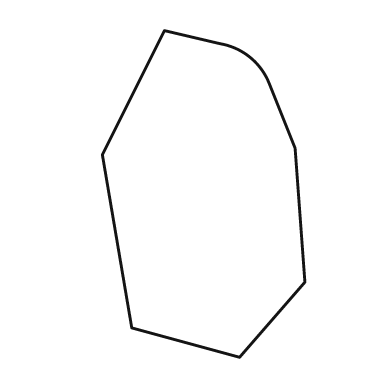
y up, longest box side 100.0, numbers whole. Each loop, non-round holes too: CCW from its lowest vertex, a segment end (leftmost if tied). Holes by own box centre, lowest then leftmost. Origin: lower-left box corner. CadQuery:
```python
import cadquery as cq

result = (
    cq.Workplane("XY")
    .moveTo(42.0, 0.0)
    .lineTo(62.0, 23.0)
    .lineTo(59.0, 64.0)
    .lineTo(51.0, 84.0)
    .threePointArc((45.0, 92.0), (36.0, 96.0))
    .lineTo(19.0, 100.0)
    .lineTo(0.0, 62.0)
    .lineTo(9.0, 9.0)
    .close()
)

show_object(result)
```